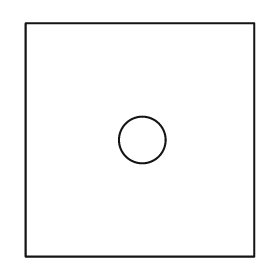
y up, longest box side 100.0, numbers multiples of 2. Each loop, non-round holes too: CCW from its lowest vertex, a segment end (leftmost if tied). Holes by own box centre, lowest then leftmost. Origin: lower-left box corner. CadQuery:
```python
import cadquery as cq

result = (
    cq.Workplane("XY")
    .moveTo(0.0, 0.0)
    .lineTo(98.0, 0.0)
    .lineTo(98.0, 100.0)
    .lineTo(0.0, 100.0)
    .close()
    .moveTo(50.0, 50.0)
    .circle(10.0)
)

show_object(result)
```